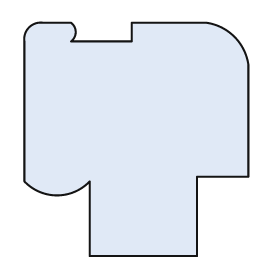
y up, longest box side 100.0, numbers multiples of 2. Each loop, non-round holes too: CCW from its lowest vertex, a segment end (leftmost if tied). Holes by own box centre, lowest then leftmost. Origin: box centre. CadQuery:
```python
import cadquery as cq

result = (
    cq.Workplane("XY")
    .moveTo(-20.0, -50.0)
    .lineTo(26.0, -50.0)
    .lineTo(26.0, -16.0)
    .lineTo(48.0, -16.0)
    .lineTo(48.0, 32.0)
    .threePointArc((42.0, 44.0), (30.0, 50.0))
    .lineTo(-2.0, 50.0)
    .lineTo(-2.0, 42.0)
    .lineTo(-28.0, 42.0)
    .threePointArc((-26.0, 46.0), (-28.0, 50.0))
    .lineTo(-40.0, 50.0)
    .threePointArc((-46.0, 48.0), (-48.0, 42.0))
    .lineTo(-48.0, -18.0)
    .threePointArc((-34.0, -24.0), (-20.0, -18.0))
    .close()
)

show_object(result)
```